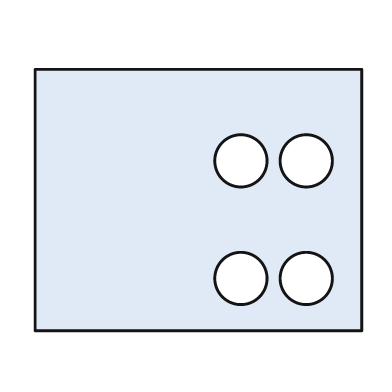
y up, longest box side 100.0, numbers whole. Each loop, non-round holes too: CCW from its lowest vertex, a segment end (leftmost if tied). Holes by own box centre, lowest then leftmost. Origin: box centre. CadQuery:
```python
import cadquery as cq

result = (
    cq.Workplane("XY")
    .moveTo(-50.0, -40.0)
    .lineTo(50.0, -40.0)
    .lineTo(50.0, 40.0)
    .lineTo(-50.0, 40.0)
    .close()
    .moveTo(13.0, -24.0)
    .circle(8.0)
    .moveTo(33.0, -24.0)
    .circle(8.0)
    .moveTo(13.0, 12.0)
    .circle(8.0)
    .moveTo(33.0, 12.0)
    .circle(8.0)
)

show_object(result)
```